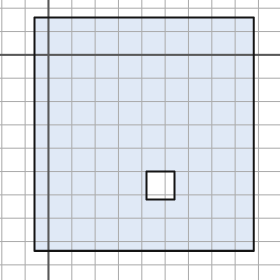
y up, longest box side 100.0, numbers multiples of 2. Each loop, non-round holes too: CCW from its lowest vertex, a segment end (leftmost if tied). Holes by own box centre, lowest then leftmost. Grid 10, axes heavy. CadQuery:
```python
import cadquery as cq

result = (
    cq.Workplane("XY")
    .moveTo(-6.0, -84.0)
    .lineTo(88.0, -84.0)
    .lineTo(88.0, 16.0)
    .lineTo(-6.0, 16.0)
    .close()
    .moveTo(42.0, -62.0)
    .lineTo(54.0, -62.0)
    .lineTo(54.0, -50.0)
    .lineTo(42.0, -50.0)
    .close()
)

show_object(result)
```